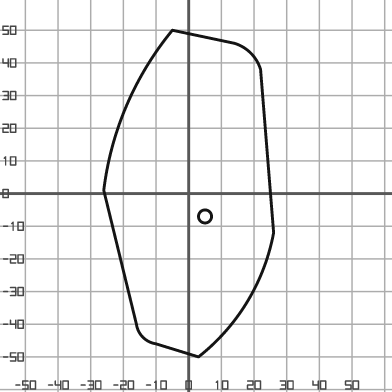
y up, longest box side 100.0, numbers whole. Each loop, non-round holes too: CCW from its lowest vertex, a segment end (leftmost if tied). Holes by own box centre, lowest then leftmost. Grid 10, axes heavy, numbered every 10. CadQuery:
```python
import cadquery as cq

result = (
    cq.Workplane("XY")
    .moveTo(3.0, -50.0)
    .threePointArc((18.0, -33.0), (26.0, -12.0))
    .lineTo(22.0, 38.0)
    .threePointArc((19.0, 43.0), (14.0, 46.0))
    .lineTo(-5.0, 50.0)
    .threePointArc((-19.0, 27.0), (-26.0, 1.0))
    .lineTo(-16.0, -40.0)
    .threePointArc((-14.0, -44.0), (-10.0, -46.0))
    .close()
    .moveTo(5.0, -7.0)
    .circle(2.0)
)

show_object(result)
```